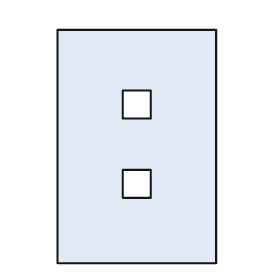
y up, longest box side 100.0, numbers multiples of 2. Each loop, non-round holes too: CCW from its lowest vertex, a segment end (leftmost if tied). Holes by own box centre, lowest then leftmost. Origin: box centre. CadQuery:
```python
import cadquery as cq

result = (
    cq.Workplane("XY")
    .moveTo(-34.0, -50.0)
    .lineTo(34.0, -50.0)
    .lineTo(34.0, 50.0)
    .lineTo(-34.0, 50.0)
    .close()
    .moveTo(-6.0, -22.0)
    .lineTo(6.0, -22.0)
    .lineTo(6.0, -10.0)
    .lineTo(-6.0, -10.0)
    .close()
    .moveTo(-6.0, 12.0)
    .lineTo(6.0, 12.0)
    .lineTo(6.0, 24.0)
    .lineTo(-6.0, 24.0)
    .close()
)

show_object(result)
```